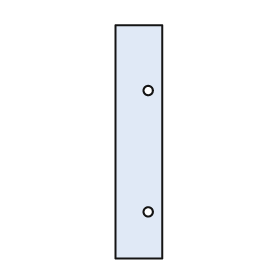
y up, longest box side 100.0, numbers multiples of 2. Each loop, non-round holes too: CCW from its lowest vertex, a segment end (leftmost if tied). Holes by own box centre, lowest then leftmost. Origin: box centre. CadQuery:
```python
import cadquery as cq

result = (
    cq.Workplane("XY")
    .moveTo(-10.0, -50.0)
    .lineTo(10.0, -50.0)
    .lineTo(10.0, 50.0)
    .lineTo(-10.0, 50.0)
    .close()
    .moveTo(4.0, -30.0)
    .circle(2.0)
    .moveTo(4.0, 22.0)
    .circle(2.0)
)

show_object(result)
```